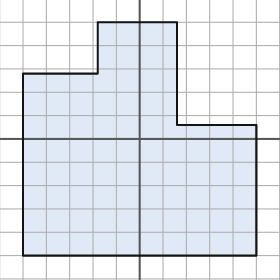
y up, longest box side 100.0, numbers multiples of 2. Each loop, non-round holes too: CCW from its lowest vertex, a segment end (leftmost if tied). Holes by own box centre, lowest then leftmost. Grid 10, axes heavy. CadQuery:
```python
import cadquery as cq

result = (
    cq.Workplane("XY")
    .moveTo(-50.0, -50.0)
    .lineTo(50.0, -50.0)
    .lineTo(50.0, 6.0)
    .lineTo(16.0, 6.0)
    .lineTo(16.0, 50.0)
    .lineTo(-18.0, 50.0)
    .lineTo(-18.0, 28.0)
    .lineTo(-50.0, 28.0)
    .close()
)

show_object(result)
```